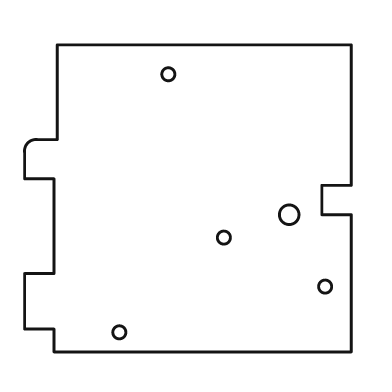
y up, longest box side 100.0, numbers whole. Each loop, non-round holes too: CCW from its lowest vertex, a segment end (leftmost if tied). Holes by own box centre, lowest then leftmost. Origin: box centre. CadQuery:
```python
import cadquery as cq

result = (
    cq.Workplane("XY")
    .moveTo(-41.0, -47.0)
    .lineTo(50.0, -47.0)
    .lineTo(50.0, -5.0)
    .lineTo(41.0, -5.0)
    .lineTo(41.0, 4.0)
    .lineTo(50.0, 4.0)
    .lineTo(50.0, 47.0)
    .lineTo(-40.0, 47.0)
    .lineTo(-40.0, 18.0)
    .lineTo(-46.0, 18.0)
    .threePointArc((-49.0, 17.0), (-50.0, 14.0))
    .lineTo(-50.0, 6.0)
    .lineTo(-41.0, 6.0)
    .lineTo(-41.0, -23.0)
    .lineTo(-50.0, -23.0)
    .lineTo(-50.0, -40.0)
    .lineTo(-41.0, -40.0)
    .close()
    .moveTo(-21.0, -41.0)
    .circle(2.0)
    .moveTo(42.0, -27.0)
    .circle(2.0)
    .moveTo(11.0, -12.0)
    .circle(2.0)
    .moveTo(31.0, -5.0)
    .circle(3.0)
    .moveTo(-6.0, 38.0)
    .circle(2.0)
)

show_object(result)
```